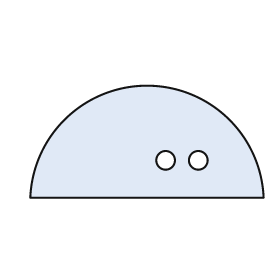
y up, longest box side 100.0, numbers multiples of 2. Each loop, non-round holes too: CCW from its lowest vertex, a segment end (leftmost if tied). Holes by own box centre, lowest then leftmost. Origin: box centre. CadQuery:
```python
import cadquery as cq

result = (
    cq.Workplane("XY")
    .moveTo(-50.0, -24.0)
    .lineTo(50.0, -24.0)
    .threePointArc((0.0, 24.0), (-50.0, -24.0))
    .close()
    .moveTo(8.0, -8.0)
    .circle(4.0)
    .moveTo(22.0, -8.0)
    .circle(4.0)
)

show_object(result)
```